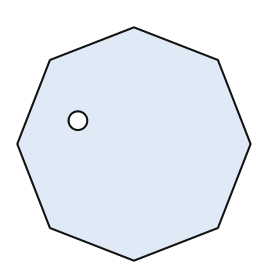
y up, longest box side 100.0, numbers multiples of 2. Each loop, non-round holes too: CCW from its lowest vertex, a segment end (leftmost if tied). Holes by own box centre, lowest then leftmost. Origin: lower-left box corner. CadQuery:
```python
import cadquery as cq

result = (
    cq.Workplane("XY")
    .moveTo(50.0, 0.0)
    .lineTo(86.0, 14.0)
    .lineTo(100.0, 50.0)
    .lineTo(86.0, 86.0)
    .lineTo(50.0, 100.0)
    .lineTo(14.0, 86.0)
    .lineTo(0.0, 50.0)
    .lineTo(14.0, 14.0)
    .close()
    .moveTo(26.0, 60.0)
    .circle(4.0)
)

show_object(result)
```